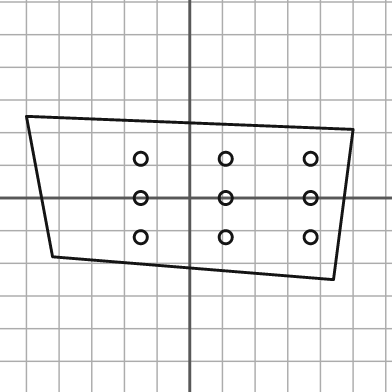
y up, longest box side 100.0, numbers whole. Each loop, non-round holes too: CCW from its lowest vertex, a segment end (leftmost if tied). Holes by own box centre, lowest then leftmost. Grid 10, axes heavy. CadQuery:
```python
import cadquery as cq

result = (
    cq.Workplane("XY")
    .moveTo(44.0, -25.0)
    .lineTo(50.0, 21.0)
    .lineTo(-50.0, 25.0)
    .lineTo(-42.0, -18.0)
    .close()
    .moveTo(-15.0, -12.0)
    .circle(2.0)
    .moveTo(11.0, -12.0)
    .circle(2.0)
    .moveTo(37.0, -12.0)
    .circle(2.0)
    .moveTo(-15.0, 0.0)
    .circle(2.0)
    .moveTo(11.0, 0.0)
    .circle(2.0)
    .moveTo(37.0, 0.0)
    .circle(2.0)
    .moveTo(-15.0, 12.0)
    .circle(2.0)
    .moveTo(11.0, 12.0)
    .circle(2.0)
    .moveTo(37.0, 12.0)
    .circle(2.0)
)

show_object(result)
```